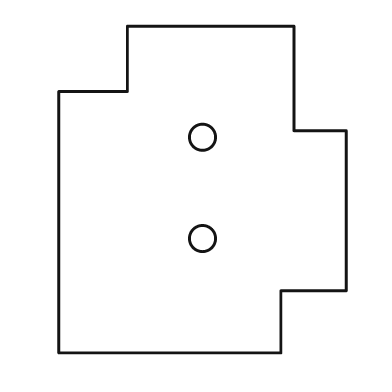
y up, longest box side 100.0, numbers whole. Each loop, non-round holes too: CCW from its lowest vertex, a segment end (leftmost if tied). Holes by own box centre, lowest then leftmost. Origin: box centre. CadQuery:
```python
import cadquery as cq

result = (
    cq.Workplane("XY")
    .moveTo(-44.0, -50.0)
    .lineTo(24.0, -50.0)
    .lineTo(24.0, -31.0)
    .lineTo(44.0, -31.0)
    .lineTo(44.0, 18.0)
    .lineTo(28.0, 18.0)
    .lineTo(28.0, 50.0)
    .lineTo(-23.0, 50.0)
    .lineTo(-23.0, 30.0)
    .lineTo(-44.0, 30.0)
    .close()
    .moveTo(0.0, -15.0)
    .circle(4.0)
    .moveTo(0.0, 16.0)
    .circle(4.0)
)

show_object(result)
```